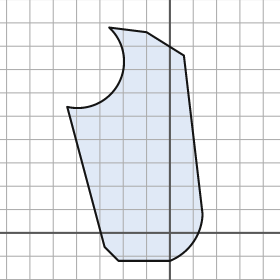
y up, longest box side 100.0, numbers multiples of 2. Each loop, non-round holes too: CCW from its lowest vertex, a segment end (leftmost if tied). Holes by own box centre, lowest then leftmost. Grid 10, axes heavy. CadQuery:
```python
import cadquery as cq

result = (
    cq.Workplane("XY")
    .moveTo(-22.0, -12.0)
    .lineTo(0.0, -12.0)
    .threePointArc((10.0, -4.0), (14.0, 8.0))
    .lineTo(6.0, 76.0)
    .lineTo(-10.0, 86.0)
    .lineTo(-26.0, 88.0)
    .threePointArc((-22.0, 64.0), (-44.0, 54.0))
    .lineTo(-28.0, -6.0)
    .close()
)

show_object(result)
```